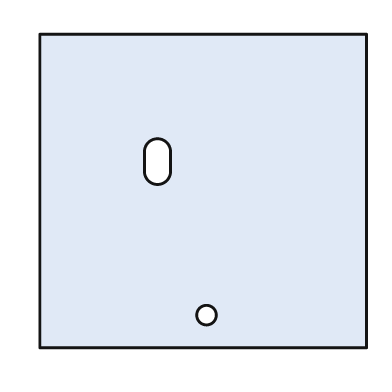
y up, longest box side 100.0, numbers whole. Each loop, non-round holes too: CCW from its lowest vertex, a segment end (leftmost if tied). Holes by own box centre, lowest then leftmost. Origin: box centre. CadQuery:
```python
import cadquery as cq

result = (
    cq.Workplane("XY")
    .moveTo(-50.0, -48.0)
    .lineTo(50.0, -48.0)
    .lineTo(50.0, 48.0)
    .lineTo(-50.0, 48.0)
    .close()
    .moveTo(1.0, -38.0)
    .circle(3.0)
    .moveTo(-18.0, 6.0)
    .threePointArc((-14.0, 2.0), (-10.0, 6.0))
    .lineTo(-10.0, 12.0)
    .threePointArc((-14.0, 16.0), (-18.0, 12.0))
    .close()
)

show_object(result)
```